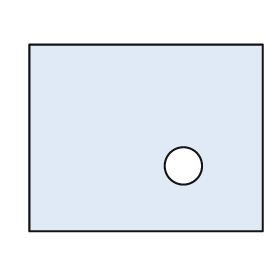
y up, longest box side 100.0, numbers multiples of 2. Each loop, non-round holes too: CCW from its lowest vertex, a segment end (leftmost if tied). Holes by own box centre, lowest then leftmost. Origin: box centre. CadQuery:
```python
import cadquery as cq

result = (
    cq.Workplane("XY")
    .moveTo(-50.0, -40.0)
    .lineTo(50.0, -40.0)
    .lineTo(50.0, 40.0)
    .lineTo(-50.0, 40.0)
    .close()
    .moveTo(16.0, -12.0)
    .circle(8.0)
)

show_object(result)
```